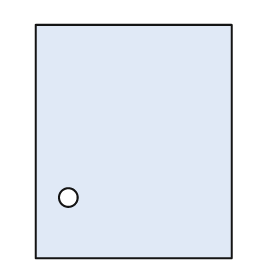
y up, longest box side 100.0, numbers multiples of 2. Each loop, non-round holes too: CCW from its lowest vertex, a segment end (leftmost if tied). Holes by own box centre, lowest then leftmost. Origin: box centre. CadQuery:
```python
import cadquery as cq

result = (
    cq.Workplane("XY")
    .moveTo(-42.0, -50.0)
    .lineTo(42.0, -50.0)
    .lineTo(42.0, 50.0)
    .lineTo(-42.0, 50.0)
    .close()
    .moveTo(-28.0, -24.0)
    .circle(4.0)
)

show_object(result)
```